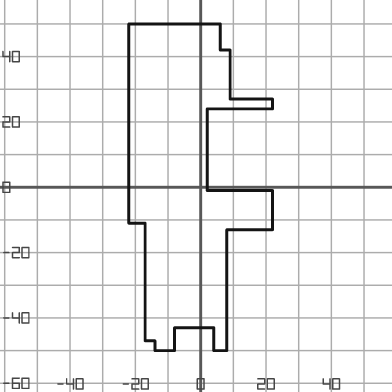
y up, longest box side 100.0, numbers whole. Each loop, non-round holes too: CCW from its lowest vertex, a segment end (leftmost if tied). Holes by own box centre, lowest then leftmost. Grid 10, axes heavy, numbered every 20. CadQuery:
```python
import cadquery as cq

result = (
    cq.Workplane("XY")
    .moveTo(-14.0, -50.0)
    .lineTo(-8.0, -50.0)
    .lineTo(-8.0, -43.0)
    .lineTo(4.0, -43.0)
    .lineTo(4.0, -50.0)
    .lineTo(8.0, -50.0)
    .lineTo(8.0, -13.0)
    .lineTo(22.0, -13.0)
    .lineTo(22.0, -1.0)
    .lineTo(2.0, -1.0)
    .lineTo(2.0, 24.0)
    .lineTo(22.0, 24.0)
    .lineTo(22.0, 27.0)
    .lineTo(9.0, 27.0)
    .lineTo(9.0, 42.0)
    .lineTo(6.0, 42.0)
    .lineTo(6.0, 50.0)
    .lineTo(-22.0, 50.0)
    .lineTo(-22.0, -11.0)
    .lineTo(-17.0, -11.0)
    .lineTo(-17.0, -47.0)
    .lineTo(-14.0, -47.0)
    .close()
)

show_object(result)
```